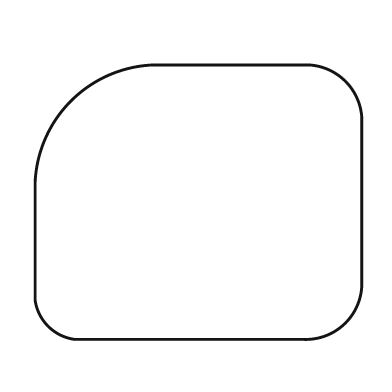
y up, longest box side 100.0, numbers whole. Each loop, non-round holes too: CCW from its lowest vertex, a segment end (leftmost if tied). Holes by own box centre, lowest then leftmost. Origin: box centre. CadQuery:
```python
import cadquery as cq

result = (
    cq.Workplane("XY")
    .moveTo(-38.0, -42.0)
    .lineTo(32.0, -42.0)
    .threePointArc((45.0, -37.0), (50.0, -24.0))
    .lineTo(50.0, 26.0)
    .threePointArc((45.0, 37.0), (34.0, 42.0))
    .lineTo(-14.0, 42.0)
    .threePointArc((-39.0, 31.0), (-50.0, 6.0))
    .lineTo(-50.0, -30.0)
    .threePointArc((-46.0, -38.0), (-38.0, -42.0))
    .close()
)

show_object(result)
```